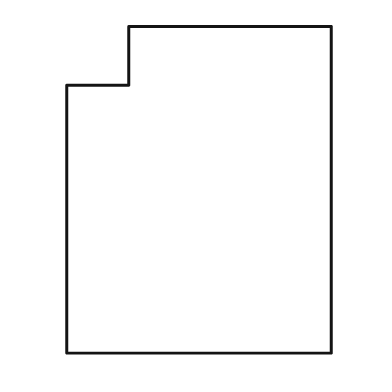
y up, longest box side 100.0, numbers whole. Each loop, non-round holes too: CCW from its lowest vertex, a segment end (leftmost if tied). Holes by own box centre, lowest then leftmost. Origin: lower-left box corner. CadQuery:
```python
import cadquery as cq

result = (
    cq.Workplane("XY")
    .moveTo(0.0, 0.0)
    .lineTo(81.0, 0.0)
    .lineTo(81.0, 100.0)
    .lineTo(19.0, 100.0)
    .lineTo(19.0, 82.0)
    .lineTo(0.0, 82.0)
    .close()
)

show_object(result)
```